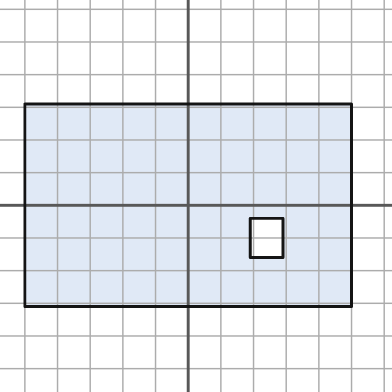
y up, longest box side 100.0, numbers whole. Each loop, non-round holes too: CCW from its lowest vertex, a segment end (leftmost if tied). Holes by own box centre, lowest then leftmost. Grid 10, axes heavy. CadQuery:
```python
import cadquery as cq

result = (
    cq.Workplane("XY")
    .moveTo(-50.0, -31.0)
    .lineTo(50.0, -31.0)
    .lineTo(50.0, 31.0)
    .lineTo(-50.0, 31.0)
    .close()
    .moveTo(19.0, -16.0)
    .lineTo(29.0, -16.0)
    .lineTo(29.0, -4.0)
    .lineTo(19.0, -4.0)
    .close()
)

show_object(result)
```